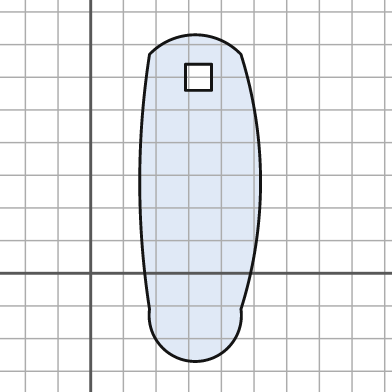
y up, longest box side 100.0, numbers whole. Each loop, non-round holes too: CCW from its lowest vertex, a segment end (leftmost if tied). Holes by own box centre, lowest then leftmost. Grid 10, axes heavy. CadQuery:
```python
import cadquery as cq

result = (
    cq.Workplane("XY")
    .moveTo(18.0, -11.0)
    .threePointArc((32.0, -27.0), (46.0, -11.0))
    .threePointArc((52.0, 28.0), (46.0, 67.0))
    .threePointArc((32.0, 73.0), (18.0, 67.0))
    .threePointArc((15.0, 28.0), (18.0, -11.0))
    .close()
    .moveTo(29.0, 56.0)
    .lineTo(37.0, 56.0)
    .lineTo(37.0, 64.0)
    .lineTo(29.0, 64.0)
    .close()
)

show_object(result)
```